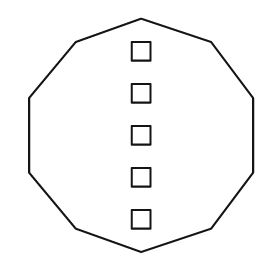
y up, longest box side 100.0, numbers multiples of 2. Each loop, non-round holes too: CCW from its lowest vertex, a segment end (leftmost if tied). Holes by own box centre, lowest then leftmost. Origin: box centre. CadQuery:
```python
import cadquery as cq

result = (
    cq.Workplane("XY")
    .moveTo(0.0, -50.0)
    .lineTo(30.0, -40.0)
    .lineTo(48.0, -16.0)
    .lineTo(48.0, 16.0)
    .lineTo(30.0, 40.0)
    .lineTo(0.0, 50.0)
    .lineTo(-28.0, 40.0)
    .lineTo(-48.0, 16.0)
    .lineTo(-48.0, -16.0)
    .lineTo(-28.0, -40.0)
    .close()
    .moveTo(-4.0, -40.0)
    .lineTo(4.0, -40.0)
    .lineTo(4.0, -32.0)
    .lineTo(-4.0, -32.0)
    .close()
    .moveTo(-4.0, -22.0)
    .lineTo(4.0, -22.0)
    .lineTo(4.0, -14.0)
    .lineTo(-4.0, -14.0)
    .close()
    .moveTo(-4.0, -4.0)
    .lineTo(4.0, -4.0)
    .lineTo(4.0, 4.0)
    .lineTo(-4.0, 4.0)
    .close()
    .moveTo(-4.0, 14.0)
    .lineTo(4.0, 14.0)
    .lineTo(4.0, 22.0)
    .lineTo(-4.0, 22.0)
    .close()
    .moveTo(-4.0, 32.0)
    .lineTo(4.0, 32.0)
    .lineTo(4.0, 40.0)
    .lineTo(-4.0, 40.0)
    .close()
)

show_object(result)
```